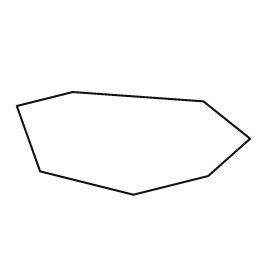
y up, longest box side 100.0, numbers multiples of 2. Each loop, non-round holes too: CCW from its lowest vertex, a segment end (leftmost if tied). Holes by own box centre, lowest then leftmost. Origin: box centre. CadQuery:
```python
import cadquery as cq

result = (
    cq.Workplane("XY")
    .moveTo(0.0, -22.0)
    .lineTo(32.0, -14.0)
    .lineTo(50.0, 2.0)
    .lineTo(30.0, 18.0)
    .lineTo(-26.0, 22.0)
    .lineTo(-50.0, 16.0)
    .lineTo(-40.0, -12.0)
    .close()
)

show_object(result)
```